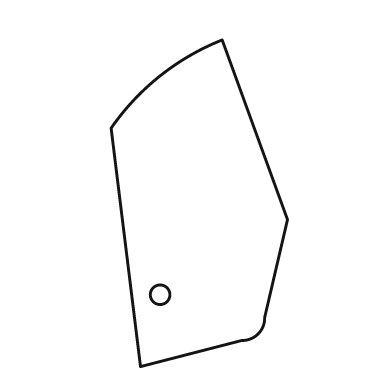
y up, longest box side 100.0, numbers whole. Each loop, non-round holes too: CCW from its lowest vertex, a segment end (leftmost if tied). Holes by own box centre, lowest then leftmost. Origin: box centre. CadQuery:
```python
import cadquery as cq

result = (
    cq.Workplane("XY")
    .moveTo(-18.0, -50.0)
    .lineTo(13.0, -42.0)
    .threePointArc((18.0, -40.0), (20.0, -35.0))
    .lineTo(27.0, -5.0)
    .lineTo(7.0, 50.0)
    .threePointArc((-12.0, 39.0), (-27.0, 23.0))
    .close()
    .moveTo(-12.0, -28.0)
    .circle(3.0)
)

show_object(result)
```